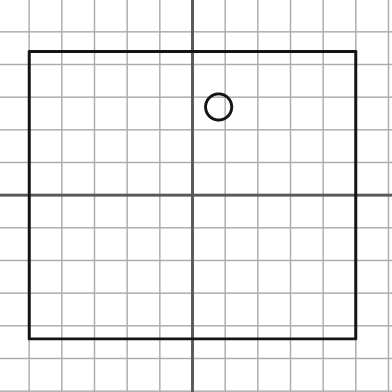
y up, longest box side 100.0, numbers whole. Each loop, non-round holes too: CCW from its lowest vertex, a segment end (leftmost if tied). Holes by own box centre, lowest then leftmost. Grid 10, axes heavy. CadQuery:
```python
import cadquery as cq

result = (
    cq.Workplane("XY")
    .moveTo(-50.0, -44.0)
    .lineTo(50.0, -44.0)
    .lineTo(50.0, 44.0)
    .lineTo(-50.0, 44.0)
    .close()
    .moveTo(8.0, 27.0)
    .circle(4.0)
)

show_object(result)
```